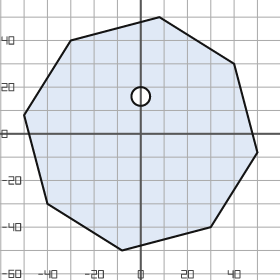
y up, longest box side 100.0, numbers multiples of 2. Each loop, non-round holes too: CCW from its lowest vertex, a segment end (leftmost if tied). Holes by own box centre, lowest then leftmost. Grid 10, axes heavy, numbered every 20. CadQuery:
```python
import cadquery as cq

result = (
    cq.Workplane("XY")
    .moveTo(-8.0, -50.0)
    .lineTo(30.0, -40.0)
    .lineTo(50.0, -8.0)
    .lineTo(40.0, 30.0)
    .lineTo(8.0, 50.0)
    .lineTo(-30.0, 40.0)
    .lineTo(-50.0, 8.0)
    .lineTo(-40.0, -30.0)
    .close()
    .moveTo(0.0, 16.0)
    .circle(4.0)
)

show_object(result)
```